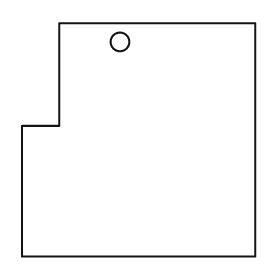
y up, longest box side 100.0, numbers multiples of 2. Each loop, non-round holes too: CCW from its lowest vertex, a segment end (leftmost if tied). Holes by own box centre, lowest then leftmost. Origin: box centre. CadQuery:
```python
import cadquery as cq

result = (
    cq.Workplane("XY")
    .moveTo(-50.0, -50.0)
    .lineTo(50.0, -50.0)
    .lineTo(50.0, 50.0)
    .lineTo(-34.0, 50.0)
    .lineTo(-34.0, 6.0)
    .lineTo(-50.0, 6.0)
    .close()
    .moveTo(-8.0, 42.0)
    .circle(4.0)
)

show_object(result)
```